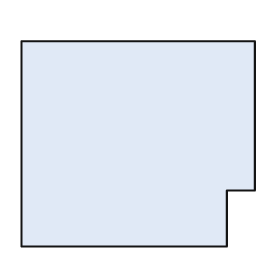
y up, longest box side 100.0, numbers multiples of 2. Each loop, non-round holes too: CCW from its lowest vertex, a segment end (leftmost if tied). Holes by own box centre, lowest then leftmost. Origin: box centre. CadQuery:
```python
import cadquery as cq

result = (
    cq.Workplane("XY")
    .moveTo(-50.0, -44.0)
    .lineTo(38.0, -44.0)
    .lineTo(38.0, -20.0)
    .lineTo(50.0, -20.0)
    .lineTo(50.0, 44.0)
    .lineTo(-50.0, 44.0)
    .close()
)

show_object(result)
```